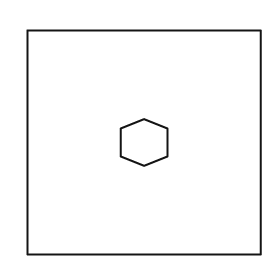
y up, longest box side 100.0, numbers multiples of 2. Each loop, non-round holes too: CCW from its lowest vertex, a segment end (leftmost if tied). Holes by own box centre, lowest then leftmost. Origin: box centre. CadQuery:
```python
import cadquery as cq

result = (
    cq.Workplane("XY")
    .moveTo(-50.0, -48.0)
    .lineTo(50.0, -48.0)
    .lineTo(50.0, 48.0)
    .lineTo(-50.0, 48.0)
    .close()
    .moveTo(0.0, -10.0)
    .lineTo(10.0, -6.0)
    .lineTo(10.0, 6.0)
    .lineTo(0.0, 10.0)
    .lineTo(-10.0, 6.0)
    .lineTo(-10.0, -6.0)
    .close()
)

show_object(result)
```